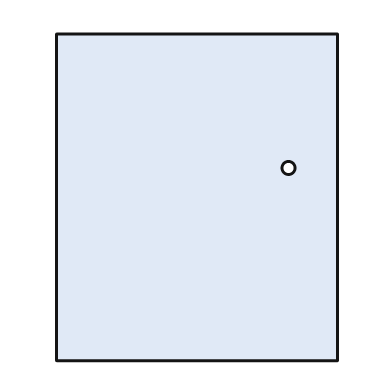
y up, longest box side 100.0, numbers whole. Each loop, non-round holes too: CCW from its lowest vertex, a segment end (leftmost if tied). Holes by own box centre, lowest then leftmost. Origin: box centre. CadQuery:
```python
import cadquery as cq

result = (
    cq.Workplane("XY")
    .moveTo(-43.0, -50.0)
    .lineTo(43.0, -50.0)
    .lineTo(43.0, 50.0)
    .lineTo(-43.0, 50.0)
    .close()
    .moveTo(28.0, 9.0)
    .circle(2.0)
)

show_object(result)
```